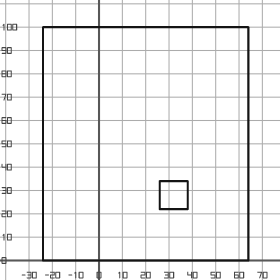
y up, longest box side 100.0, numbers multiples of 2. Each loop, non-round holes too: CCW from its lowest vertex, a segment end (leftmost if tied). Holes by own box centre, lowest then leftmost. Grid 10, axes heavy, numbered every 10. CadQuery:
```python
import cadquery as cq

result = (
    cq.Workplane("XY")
    .moveTo(-24.0, 0.0)
    .lineTo(64.0, 0.0)
    .lineTo(64.0, 100.0)
    .lineTo(-24.0, 100.0)
    .close()
    .moveTo(26.0, 22.0)
    .lineTo(38.0, 22.0)
    .lineTo(38.0, 34.0)
    .lineTo(26.0, 34.0)
    .close()
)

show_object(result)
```